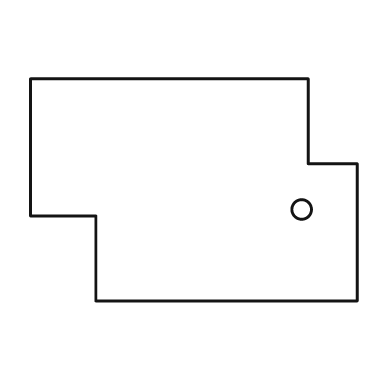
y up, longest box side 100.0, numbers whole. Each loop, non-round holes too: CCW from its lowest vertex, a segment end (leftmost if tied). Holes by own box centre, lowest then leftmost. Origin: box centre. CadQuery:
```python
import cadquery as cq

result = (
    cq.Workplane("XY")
    .moveTo(-30.0, -34.0)
    .lineTo(50.0, -34.0)
    .lineTo(50.0, 8.0)
    .lineTo(35.0, 8.0)
    .lineTo(35.0, 34.0)
    .lineTo(-50.0, 34.0)
    .lineTo(-50.0, -8.0)
    .lineTo(-30.0, -8.0)
    .close()
    .moveTo(33.0, -6.0)
    .circle(3.0)
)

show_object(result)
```